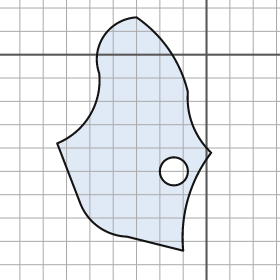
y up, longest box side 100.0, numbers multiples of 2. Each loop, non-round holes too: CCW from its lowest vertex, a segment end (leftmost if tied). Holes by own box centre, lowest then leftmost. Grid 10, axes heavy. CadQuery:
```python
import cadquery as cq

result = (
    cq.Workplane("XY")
    .moveTo(-10.0, -84.0)
    .threePointArc((-8.0, -62.0), (2.0, -42.0))
    .threePointArc((-6.0, -30.0), (-8.0, -16.0))
    .threePointArc((-16.0, 2.0), (-30.0, 16.0))
    .threePointArc((-44.0, 8.0), (-46.0, -8.0))
    .threePointArc((-50.0, -26.0), (-64.0, -38.0))
    .lineTo(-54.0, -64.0)
    .threePointArc((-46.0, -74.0), (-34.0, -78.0))
    .close()
    .moveTo(-14.0, -50.0)
    .circle(6.0)
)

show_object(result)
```